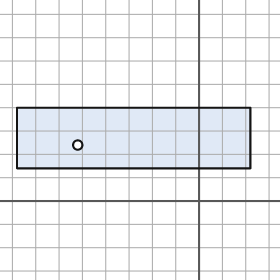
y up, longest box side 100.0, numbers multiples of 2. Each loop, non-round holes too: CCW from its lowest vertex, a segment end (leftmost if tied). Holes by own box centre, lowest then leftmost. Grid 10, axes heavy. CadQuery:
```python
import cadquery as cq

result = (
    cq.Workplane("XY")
    .moveTo(-78.0, 14.0)
    .lineTo(22.0, 14.0)
    .lineTo(22.0, 40.0)
    .lineTo(-78.0, 40.0)
    .close()
    .moveTo(-52.0, 24.0)
    .circle(2.0)
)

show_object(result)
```